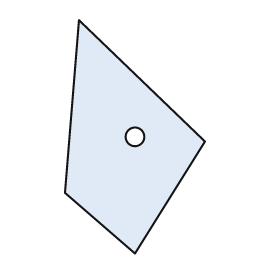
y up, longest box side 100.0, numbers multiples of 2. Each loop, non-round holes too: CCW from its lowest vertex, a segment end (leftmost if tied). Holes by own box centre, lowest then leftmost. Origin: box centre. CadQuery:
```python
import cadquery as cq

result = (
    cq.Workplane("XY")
    .moveTo(0.0, -50.0)
    .lineTo(30.0, -2.0)
    .lineTo(-24.0, 50.0)
    .lineTo(-30.0, -24.0)
    .close()
    .moveTo(0.0, 0.0)
    .circle(4.0)
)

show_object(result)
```